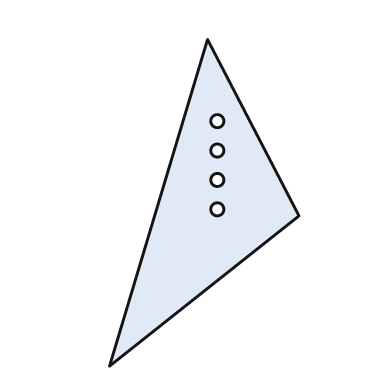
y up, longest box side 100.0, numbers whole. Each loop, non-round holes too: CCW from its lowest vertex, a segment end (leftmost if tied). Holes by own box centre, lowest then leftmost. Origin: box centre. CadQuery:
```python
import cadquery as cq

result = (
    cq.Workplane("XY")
    .moveTo(-29.0, -50.0)
    .lineTo(29.0, -4.0)
    .lineTo(1.0, 50.0)
    .close()
    .moveTo(4.0, -2.0)
    .circle(2.0)
    .moveTo(4.0, 7.0)
    .circle(2.0)
    .moveTo(4.0, 16.0)
    .circle(2.0)
    .moveTo(4.0, 25.0)
    .circle(2.0)
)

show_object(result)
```